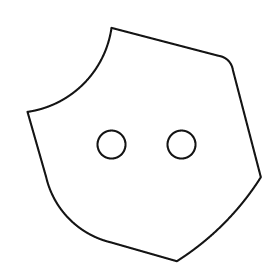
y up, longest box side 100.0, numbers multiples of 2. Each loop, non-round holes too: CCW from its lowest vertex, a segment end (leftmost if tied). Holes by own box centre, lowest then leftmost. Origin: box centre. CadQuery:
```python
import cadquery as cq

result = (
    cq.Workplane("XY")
    .moveTo(14.0, -50.0)
    .threePointArc((34.0, -34.0), (50.0, -14.0))
    .lineTo(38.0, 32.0)
    .threePointArc((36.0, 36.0), (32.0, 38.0))
    .lineTo(-14.0, 50.0)
    .threePointArc((-26.0, 26.0), (-50.0, 14.0))
    .lineTo(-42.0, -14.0)
    .threePointArc((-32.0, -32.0), (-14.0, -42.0))
    .close()
    .moveTo(-14.0, 0.0)
    .circle(6.0)
    .moveTo(16.0, 0.0)
    .circle(6.0)
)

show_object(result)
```